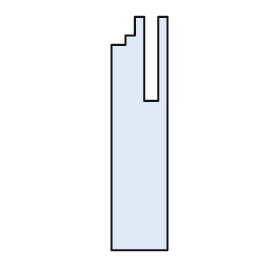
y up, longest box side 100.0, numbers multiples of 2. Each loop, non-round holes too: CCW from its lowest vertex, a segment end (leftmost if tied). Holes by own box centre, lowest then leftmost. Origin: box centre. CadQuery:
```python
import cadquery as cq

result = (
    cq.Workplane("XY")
    .moveTo(-12.0, -50.0)
    .lineTo(12.0, -50.0)
    .lineTo(12.0, 50.0)
    .lineTo(8.0, 50.0)
    .lineTo(8.0, 14.0)
    .lineTo(2.0, 14.0)
    .lineTo(2.0, 50.0)
    .lineTo(-2.0, 50.0)
    .lineTo(-2.0, 42.0)
    .lineTo(-6.0, 42.0)
    .lineTo(-6.0, 38.0)
    .lineTo(-12.0, 38.0)
    .close()
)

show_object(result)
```